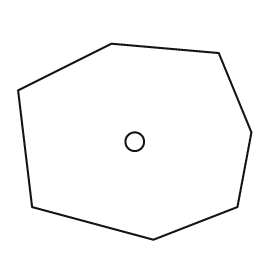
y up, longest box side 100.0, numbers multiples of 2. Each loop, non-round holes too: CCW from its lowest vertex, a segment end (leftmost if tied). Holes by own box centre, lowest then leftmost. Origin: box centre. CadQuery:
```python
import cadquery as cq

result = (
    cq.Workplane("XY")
    .moveTo(8.0, -42.0)
    .lineTo(44.0, -28.0)
    .lineTo(50.0, 4.0)
    .lineTo(36.0, 38.0)
    .lineTo(-10.0, 42.0)
    .lineTo(-50.0, 22.0)
    .lineTo(-44.0, -28.0)
    .close()
    .moveTo(0.0, 0.0)
    .circle(4.0)
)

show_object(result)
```